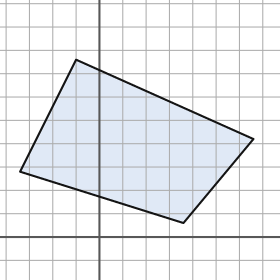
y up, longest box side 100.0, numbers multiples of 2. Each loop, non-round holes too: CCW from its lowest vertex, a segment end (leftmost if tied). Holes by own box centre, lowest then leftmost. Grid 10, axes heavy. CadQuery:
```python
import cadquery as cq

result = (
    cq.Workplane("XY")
    .moveTo(36.0, 6.0)
    .lineTo(66.0, 42.0)
    .lineTo(-10.0, 76.0)
    .lineTo(-34.0, 28.0)
    .close()
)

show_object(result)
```